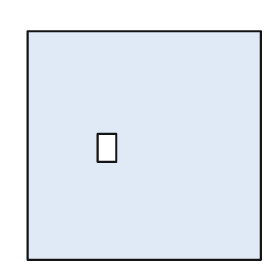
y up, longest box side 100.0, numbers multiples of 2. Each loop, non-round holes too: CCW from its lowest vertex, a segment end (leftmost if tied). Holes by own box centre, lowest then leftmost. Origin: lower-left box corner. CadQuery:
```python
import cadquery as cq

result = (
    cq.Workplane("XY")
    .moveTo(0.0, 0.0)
    .lineTo(100.0, 0.0)
    .lineTo(100.0, 98.0)
    .lineTo(0.0, 98.0)
    .close()
    .moveTo(30.0, 42.0)
    .lineTo(38.0, 42.0)
    .lineTo(38.0, 54.0)
    .lineTo(30.0, 54.0)
    .close()
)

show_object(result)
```